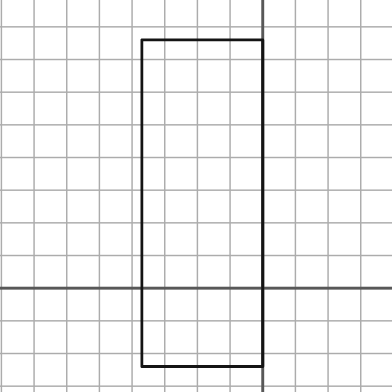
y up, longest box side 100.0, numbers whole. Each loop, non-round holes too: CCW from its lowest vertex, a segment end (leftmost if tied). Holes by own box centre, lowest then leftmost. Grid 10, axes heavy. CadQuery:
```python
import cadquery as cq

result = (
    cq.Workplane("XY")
    .moveTo(-37.0, -24.0)
    .lineTo(0.0, -24.0)
    .lineTo(0.0, 76.0)
    .lineTo(-37.0, 76.0)
    .close()
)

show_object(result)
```